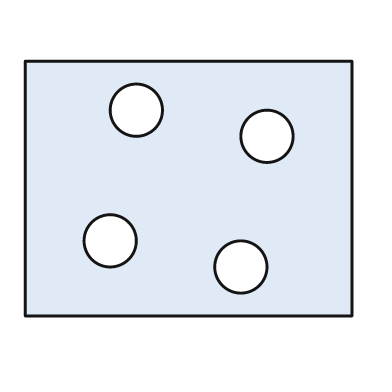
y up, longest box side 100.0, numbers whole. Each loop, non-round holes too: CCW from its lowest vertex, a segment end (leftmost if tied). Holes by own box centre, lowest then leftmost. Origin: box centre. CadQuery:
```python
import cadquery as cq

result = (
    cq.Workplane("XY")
    .moveTo(-50.0, -39.0)
    .lineTo(50.0, -39.0)
    .lineTo(50.0, 39.0)
    .lineTo(-50.0, 39.0)
    .close()
    .moveTo(16.0, -24.0)
    .circle(8.0)
    .moveTo(-24.0, -16.0)
    .circle(8.0)
    .moveTo(24.0, 16.0)
    .circle(8.0)
    .moveTo(-16.0, 24.0)
    .circle(8.0)
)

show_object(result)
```